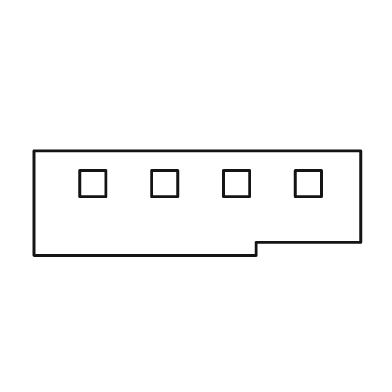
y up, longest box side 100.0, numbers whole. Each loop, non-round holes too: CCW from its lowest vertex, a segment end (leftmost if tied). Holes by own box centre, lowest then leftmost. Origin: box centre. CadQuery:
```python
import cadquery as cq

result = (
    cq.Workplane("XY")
    .moveTo(-50.0, -16.0)
    .lineTo(18.0, -16.0)
    .lineTo(18.0, -12.0)
    .lineTo(50.0, -12.0)
    .lineTo(50.0, 16.0)
    .lineTo(-50.0, 16.0)
    .close()
    .moveTo(-36.0, 2.0)
    .lineTo(-28.0, 2.0)
    .lineTo(-28.0, 10.0)
    .lineTo(-36.0, 10.0)
    .close()
    .moveTo(-14.0, 2.0)
    .lineTo(-6.0, 2.0)
    .lineTo(-6.0, 10.0)
    .lineTo(-14.0, 10.0)
    .close()
    .moveTo(8.0, 2.0)
    .lineTo(16.0, 2.0)
    .lineTo(16.0, 10.0)
    .lineTo(8.0, 10.0)
    .close()
    .moveTo(30.0, 2.0)
    .lineTo(38.0, 2.0)
    .lineTo(38.0, 10.0)
    .lineTo(30.0, 10.0)
    .close()
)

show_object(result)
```